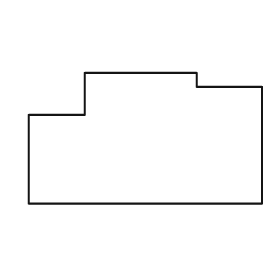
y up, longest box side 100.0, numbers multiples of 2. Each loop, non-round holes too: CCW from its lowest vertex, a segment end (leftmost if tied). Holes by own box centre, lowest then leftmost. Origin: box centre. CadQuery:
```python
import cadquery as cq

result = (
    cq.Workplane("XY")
    .moveTo(-50.0, -28.0)
    .lineTo(50.0, -28.0)
    .lineTo(50.0, 22.0)
    .lineTo(22.0, 22.0)
    .lineTo(22.0, 28.0)
    .lineTo(-26.0, 28.0)
    .lineTo(-26.0, 10.0)
    .lineTo(-50.0, 10.0)
    .close()
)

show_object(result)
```